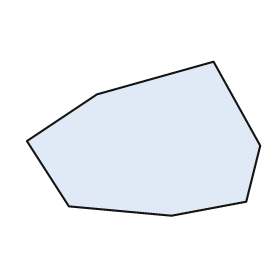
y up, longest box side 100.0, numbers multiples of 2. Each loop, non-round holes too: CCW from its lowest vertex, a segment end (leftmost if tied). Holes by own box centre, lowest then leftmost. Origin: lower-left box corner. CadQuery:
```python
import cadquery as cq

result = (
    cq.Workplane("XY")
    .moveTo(62.0, 0.0)
    .lineTo(94.0, 6.0)
    .lineTo(100.0, 30.0)
    .lineTo(80.0, 66.0)
    .lineTo(30.0, 52.0)
    .lineTo(0.0, 32.0)
    .lineTo(18.0, 4.0)
    .close()
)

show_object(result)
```